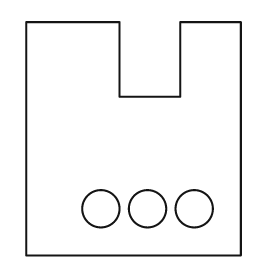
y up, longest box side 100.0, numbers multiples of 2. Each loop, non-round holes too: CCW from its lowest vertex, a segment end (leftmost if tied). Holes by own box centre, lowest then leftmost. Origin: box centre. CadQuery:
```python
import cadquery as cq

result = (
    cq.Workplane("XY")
    .moveTo(-46.0, -50.0)
    .lineTo(46.0, -50.0)
    .lineTo(46.0, 50.0)
    .lineTo(20.0, 50.0)
    .lineTo(20.0, 18.0)
    .lineTo(-6.0, 18.0)
    .lineTo(-6.0, 50.0)
    .lineTo(-46.0, 50.0)
    .close()
    .moveTo(-14.0, -30.0)
    .circle(8.0)
    .moveTo(6.0, -30.0)
    .circle(8.0)
    .moveTo(26.0, -30.0)
    .circle(8.0)
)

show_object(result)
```